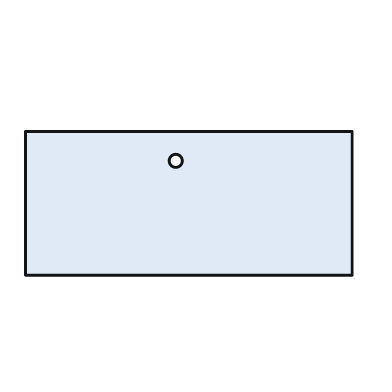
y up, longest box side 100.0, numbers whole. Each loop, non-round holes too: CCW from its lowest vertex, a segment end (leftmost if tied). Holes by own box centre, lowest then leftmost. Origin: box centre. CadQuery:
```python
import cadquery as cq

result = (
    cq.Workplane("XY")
    .moveTo(-50.0, -22.0)
    .lineTo(50.0, -22.0)
    .lineTo(50.0, 22.0)
    .lineTo(-50.0, 22.0)
    .close()
    .moveTo(-4.0, 13.0)
    .circle(2.0)
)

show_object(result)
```